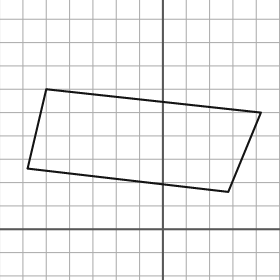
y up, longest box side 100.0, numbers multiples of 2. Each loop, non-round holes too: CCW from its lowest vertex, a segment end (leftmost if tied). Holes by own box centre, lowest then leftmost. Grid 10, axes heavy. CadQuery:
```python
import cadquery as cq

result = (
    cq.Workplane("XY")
    .moveTo(28.0, 16.0)
    .lineTo(42.0, 50.0)
    .lineTo(-50.0, 60.0)
    .lineTo(-58.0, 26.0)
    .close()
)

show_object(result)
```